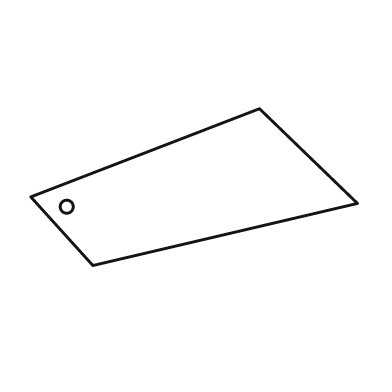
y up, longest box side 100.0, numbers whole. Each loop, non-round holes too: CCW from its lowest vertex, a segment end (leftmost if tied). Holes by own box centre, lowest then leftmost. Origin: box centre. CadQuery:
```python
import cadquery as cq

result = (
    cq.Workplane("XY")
    .moveTo(-31.0, -24.0)
    .lineTo(50.0, -5.0)
    .lineTo(20.0, 24.0)
    .lineTo(-50.0, -3.0)
    .close()
    .moveTo(-39.0, -6.0)
    .circle(2.0)
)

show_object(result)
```